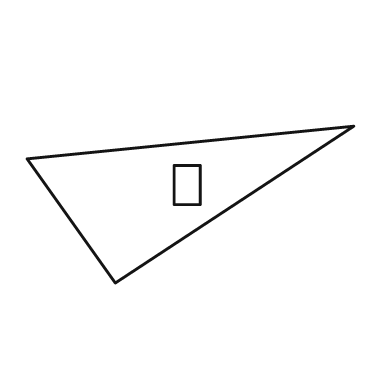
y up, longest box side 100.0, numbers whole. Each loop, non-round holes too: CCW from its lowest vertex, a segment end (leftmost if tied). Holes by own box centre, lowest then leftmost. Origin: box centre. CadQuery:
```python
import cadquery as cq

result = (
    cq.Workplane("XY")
    .moveTo(-23.0, -24.0)
    .lineTo(50.0, 24.0)
    .lineTo(-50.0, 14.0)
    .close()
    .moveTo(-5.0, 0.0)
    .lineTo(3.0, 0.0)
    .lineTo(3.0, 12.0)
    .lineTo(-5.0, 12.0)
    .close()
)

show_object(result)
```